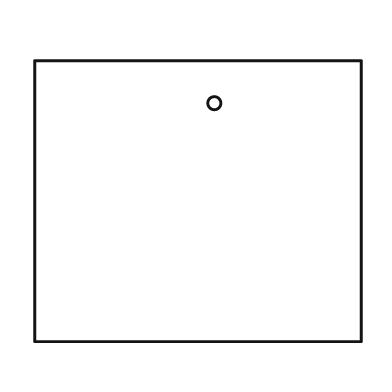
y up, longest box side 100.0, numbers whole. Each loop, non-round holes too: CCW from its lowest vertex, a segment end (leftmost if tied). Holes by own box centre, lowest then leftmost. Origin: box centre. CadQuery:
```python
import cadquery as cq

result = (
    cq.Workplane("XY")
    .moveTo(-50.0, -43.0)
    .lineTo(50.0, -43.0)
    .lineTo(50.0, 43.0)
    .lineTo(-50.0, 43.0)
    .close()
    .moveTo(5.0, 30.0)
    .circle(2.0)
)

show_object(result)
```